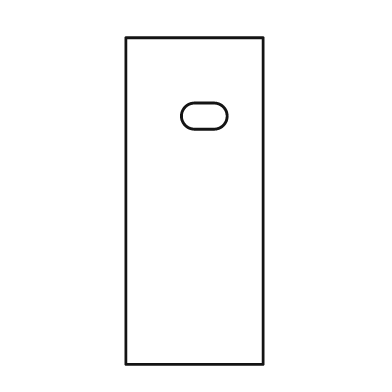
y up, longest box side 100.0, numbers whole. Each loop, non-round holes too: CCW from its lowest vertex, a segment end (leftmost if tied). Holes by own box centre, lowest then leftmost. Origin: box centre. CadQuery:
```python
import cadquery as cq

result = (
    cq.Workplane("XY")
    .moveTo(-21.0, -50.0)
    .lineTo(21.0, -50.0)
    .lineTo(21.0, 50.0)
    .lineTo(-21.0, 50.0)
    .close()
    .moveTo(0.0, 22.0)
    .lineTo(6.0, 22.0)
    .threePointArc((10.0, 26.0), (6.0, 30.0))
    .lineTo(0.0, 30.0)
    .threePointArc((-4.0, 26.0), (0.0, 22.0))
    .close()
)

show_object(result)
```